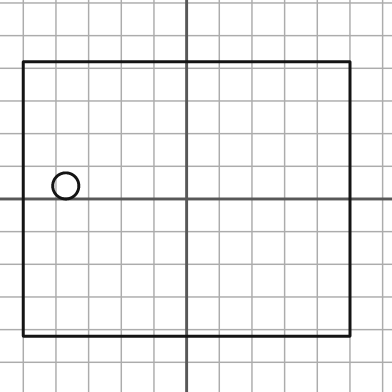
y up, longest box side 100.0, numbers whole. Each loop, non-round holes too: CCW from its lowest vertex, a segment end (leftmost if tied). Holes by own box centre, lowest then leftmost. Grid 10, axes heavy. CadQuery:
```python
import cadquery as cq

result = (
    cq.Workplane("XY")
    .moveTo(-50.0, -42.0)
    .lineTo(50.0, -42.0)
    .lineTo(50.0, 42.0)
    .lineTo(-50.0, 42.0)
    .close()
    .moveTo(-37.0, 4.0)
    .circle(4.0)
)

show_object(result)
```